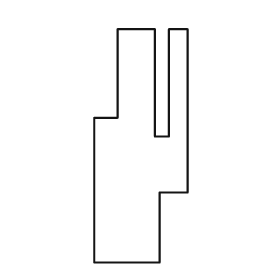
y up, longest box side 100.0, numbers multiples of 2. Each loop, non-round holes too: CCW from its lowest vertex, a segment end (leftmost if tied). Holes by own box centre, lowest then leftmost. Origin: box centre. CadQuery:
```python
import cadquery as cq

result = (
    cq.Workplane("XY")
    .moveTo(-20.0, -50.0)
    .lineTo(8.0, -50.0)
    .lineTo(8.0, -20.0)
    .lineTo(20.0, -20.0)
    .lineTo(20.0, 50.0)
    .lineTo(12.0, 50.0)
    .lineTo(12.0, 4.0)
    .lineTo(6.0, 4.0)
    .lineTo(6.0, 50.0)
    .lineTo(-10.0, 50.0)
    .lineTo(-10.0, 12.0)
    .lineTo(-20.0, 12.0)
    .close()
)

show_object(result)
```